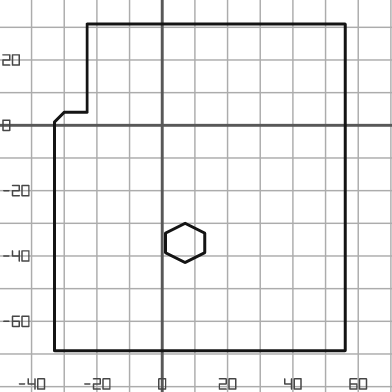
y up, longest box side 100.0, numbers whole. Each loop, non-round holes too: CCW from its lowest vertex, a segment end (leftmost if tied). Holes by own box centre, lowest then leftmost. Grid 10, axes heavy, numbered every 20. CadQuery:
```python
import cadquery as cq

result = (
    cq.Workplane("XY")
    .moveTo(-33.0, -69.0)
    .lineTo(56.0, -69.0)
    .lineTo(56.0, 31.0)
    .lineTo(-23.0, 31.0)
    .lineTo(-23.0, 4.0)
    .lineTo(-30.0, 4.0)
    .lineTo(-33.0, 1.0)
    .close()
    .moveTo(7.0, -42.0)
    .lineTo(13.0, -39.0)
    .lineTo(13.0, -33.0)
    .lineTo(7.0, -30.0)
    .lineTo(1.0, -33.0)
    .lineTo(1.0, -39.0)
    .close()
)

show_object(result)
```